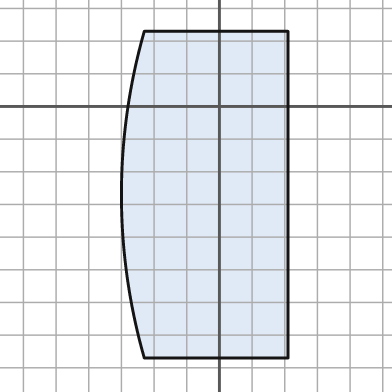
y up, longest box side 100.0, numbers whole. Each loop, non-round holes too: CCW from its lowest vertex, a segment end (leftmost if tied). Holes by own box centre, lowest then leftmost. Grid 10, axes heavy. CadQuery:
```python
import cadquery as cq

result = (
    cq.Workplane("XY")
    .moveTo(-23.0, -77.0)
    .lineTo(21.0, -77.0)
    .lineTo(21.0, 23.0)
    .lineTo(-23.0, 23.0)
    .threePointArc((-30.0, -27.0), (-23.0, -77.0))
    .close()
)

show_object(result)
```